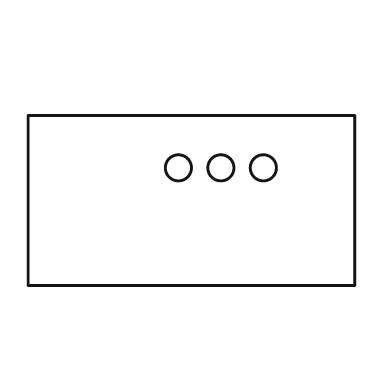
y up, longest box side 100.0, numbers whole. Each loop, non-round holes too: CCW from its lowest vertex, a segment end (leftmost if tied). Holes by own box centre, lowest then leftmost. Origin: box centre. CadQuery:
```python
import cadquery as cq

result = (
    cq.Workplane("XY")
    .moveTo(-50.0, -26.0)
    .lineTo(50.0, -26.0)
    .lineTo(50.0, 26.0)
    .lineTo(-50.0, 26.0)
    .close()
    .moveTo(-4.0, 10.0)
    .circle(4.0)
    .moveTo(9.0, 10.0)
    .circle(4.0)
    .moveTo(22.0, 10.0)
    .circle(4.0)
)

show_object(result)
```